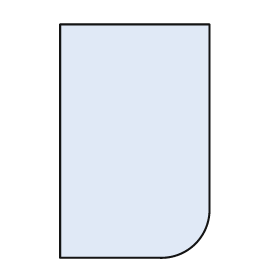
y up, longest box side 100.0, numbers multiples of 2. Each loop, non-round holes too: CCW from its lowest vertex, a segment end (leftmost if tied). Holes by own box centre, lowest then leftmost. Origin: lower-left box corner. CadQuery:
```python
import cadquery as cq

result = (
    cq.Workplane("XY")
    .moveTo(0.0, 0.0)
    .lineTo(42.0, 0.0)
    .threePointArc((58.0, 6.0), (64.0, 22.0))
    .lineTo(64.0, 100.0)
    .lineTo(0.0, 100.0)
    .close()
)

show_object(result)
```